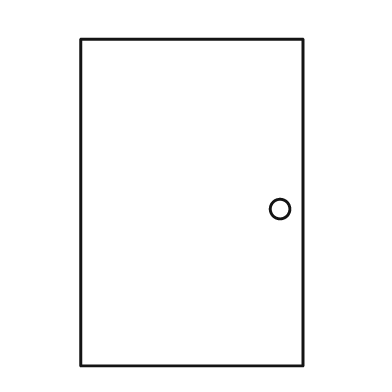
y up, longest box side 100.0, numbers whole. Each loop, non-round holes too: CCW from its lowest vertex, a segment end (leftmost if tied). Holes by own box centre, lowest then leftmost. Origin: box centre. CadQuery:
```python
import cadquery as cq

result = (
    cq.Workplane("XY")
    .moveTo(-34.0, -50.0)
    .lineTo(34.0, -50.0)
    .lineTo(34.0, 50.0)
    .lineTo(-34.0, 50.0)
    .close()
    .moveTo(27.0, -2.0)
    .circle(3.0)
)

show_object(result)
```